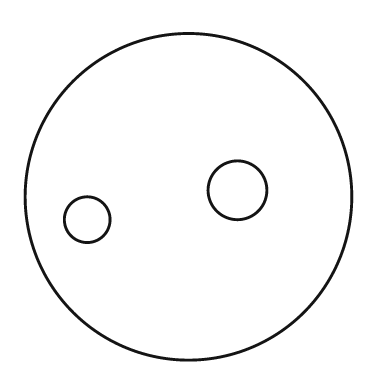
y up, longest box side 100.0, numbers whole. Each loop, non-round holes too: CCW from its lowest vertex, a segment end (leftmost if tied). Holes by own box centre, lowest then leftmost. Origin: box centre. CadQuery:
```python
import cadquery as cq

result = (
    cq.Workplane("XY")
    .moveTo(0.0, 0.0)
    .circle(50.0)
    .moveTo(-31.0, -7.0)
    .circle(7.0)
    .moveTo(15.0, 2.0)
    .circle(9.0)
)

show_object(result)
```